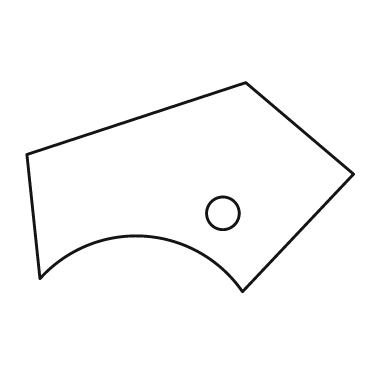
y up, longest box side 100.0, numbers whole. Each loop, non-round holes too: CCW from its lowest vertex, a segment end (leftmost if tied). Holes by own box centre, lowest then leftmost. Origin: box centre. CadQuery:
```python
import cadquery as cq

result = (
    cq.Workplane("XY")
    .moveTo(16.0, -32.0)
    .lineTo(50.0, 4.0)
    .lineTo(17.0, 32.0)
    .lineTo(-50.0, 10.0)
    .lineTo(-46.0, -28.0)
    .threePointArc((-14.0, -15.0), (16.0, -32.0))
    .close()
    .moveTo(10.0, -8.0)
    .circle(5.0)
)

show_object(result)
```